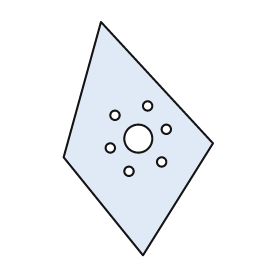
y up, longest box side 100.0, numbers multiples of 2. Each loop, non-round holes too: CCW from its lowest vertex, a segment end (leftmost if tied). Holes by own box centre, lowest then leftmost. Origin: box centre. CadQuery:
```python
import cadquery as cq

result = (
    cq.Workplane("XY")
    .moveTo(2.0, -50.0)
    .lineTo(32.0, -2.0)
    .lineTo(-16.0, 50.0)
    .lineTo(-32.0, -8.0)
    .close()
    .moveTo(-4.0, -14.0)
    .circle(2.0)
    .moveTo(10.0, -10.0)
    .circle(2.0)
    .moveTo(-12.0, -4.0)
    .circle(2.0)
    .moveTo(0.0, 0.0)
    .circle(6.0)
    .moveTo(12.0, 4.0)
    .circle(2.0)
    .moveTo(-10.0, 10.0)
    .circle(2.0)
    .moveTo(4.0, 14.0)
    .circle(2.0)
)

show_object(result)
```